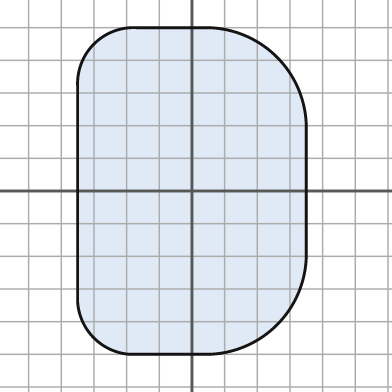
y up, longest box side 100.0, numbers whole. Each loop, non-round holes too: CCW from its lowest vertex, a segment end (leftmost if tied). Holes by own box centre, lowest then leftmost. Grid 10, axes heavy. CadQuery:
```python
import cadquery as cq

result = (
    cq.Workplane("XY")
    .moveTo(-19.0, -50.0)
    .lineTo(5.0, -50.0)
    .threePointArc((26.0, -41.0), (35.0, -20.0))
    .lineTo(35.0, 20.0)
    .threePointArc((26.0, 41.0), (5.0, 50.0))
    .lineTo(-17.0, 50.0)
    .threePointArc((-30.0, 45.0), (-35.0, 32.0))
    .lineTo(-35.0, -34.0)
    .threePointArc((-30.0, -45.0), (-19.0, -50.0))
    .close()
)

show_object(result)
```